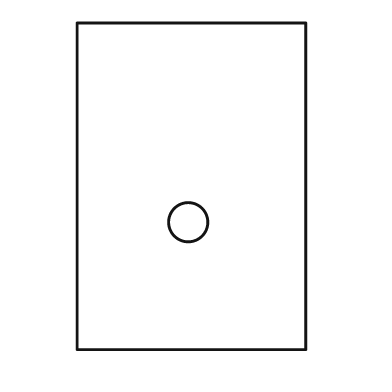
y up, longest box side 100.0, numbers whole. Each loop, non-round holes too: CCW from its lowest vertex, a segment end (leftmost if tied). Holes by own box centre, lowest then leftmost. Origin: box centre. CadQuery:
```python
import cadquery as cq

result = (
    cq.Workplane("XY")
    .moveTo(-35.0, -50.0)
    .lineTo(35.0, -50.0)
    .lineTo(35.0, 50.0)
    .lineTo(-35.0, 50.0)
    .close()
    .moveTo(-1.0, -11.0)
    .circle(6.0)
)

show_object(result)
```